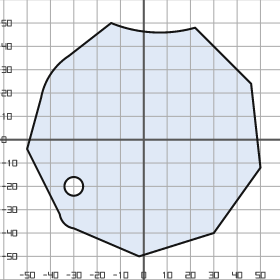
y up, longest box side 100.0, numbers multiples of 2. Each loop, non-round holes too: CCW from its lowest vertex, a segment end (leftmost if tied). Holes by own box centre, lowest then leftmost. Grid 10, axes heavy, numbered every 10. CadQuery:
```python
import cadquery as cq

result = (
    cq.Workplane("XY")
    .moveTo(-2.0, -50.0)
    .lineTo(30.0, -40.0)
    .lineTo(50.0, -12.0)
    .lineTo(46.0, 24.0)
    .lineTo(22.0, 48.0)
    .threePointArc((4.0, 46.0), (-14.0, 50.0))
    .lineTo(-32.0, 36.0)
    .threePointArc((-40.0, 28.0), (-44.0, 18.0))
    .lineTo(-50.0, -4.0)
    .lineTo(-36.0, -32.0)
    .threePointArc((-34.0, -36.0), (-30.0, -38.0))
    .close()
    .moveTo(-30.0, -20.0)
    .circle(4.0)
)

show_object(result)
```